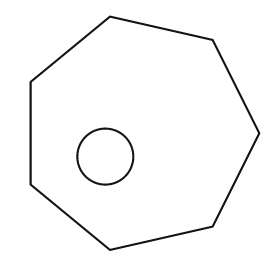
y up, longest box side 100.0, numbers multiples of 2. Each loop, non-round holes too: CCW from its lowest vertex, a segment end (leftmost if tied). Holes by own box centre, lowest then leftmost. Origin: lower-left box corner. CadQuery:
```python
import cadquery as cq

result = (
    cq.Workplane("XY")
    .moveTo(34.0, 0.0)
    .lineTo(78.0, 10.0)
    .lineTo(98.0, 50.0)
    .lineTo(78.0, 90.0)
    .lineTo(34.0, 100.0)
    .lineTo(0.0, 72.0)
    .lineTo(0.0, 28.0)
    .close()
    .moveTo(32.0, 40.0)
    .circle(12.0)
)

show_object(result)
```